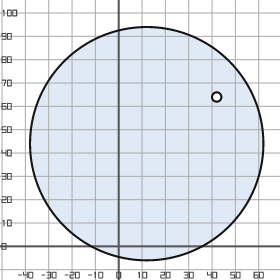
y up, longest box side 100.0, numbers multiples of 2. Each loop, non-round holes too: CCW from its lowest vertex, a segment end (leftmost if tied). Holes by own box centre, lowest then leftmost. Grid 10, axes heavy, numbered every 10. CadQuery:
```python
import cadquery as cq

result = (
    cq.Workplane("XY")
    .moveTo(12.0, 44.0)
    .circle(50.0)
    .moveTo(42.0, 64.0)
    .circle(2.0)
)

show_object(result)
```